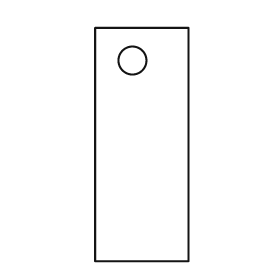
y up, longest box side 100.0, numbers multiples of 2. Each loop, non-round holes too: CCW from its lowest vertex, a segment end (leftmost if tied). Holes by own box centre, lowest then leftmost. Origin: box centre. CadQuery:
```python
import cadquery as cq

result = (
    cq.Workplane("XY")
    .moveTo(-20.0, -50.0)
    .lineTo(20.0, -50.0)
    .lineTo(20.0, 50.0)
    .lineTo(-20.0, 50.0)
    .close()
    .moveTo(-4.0, 36.0)
    .circle(6.0)
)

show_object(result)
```